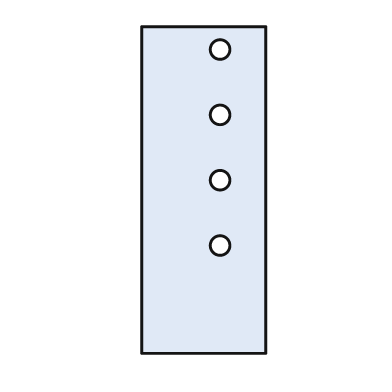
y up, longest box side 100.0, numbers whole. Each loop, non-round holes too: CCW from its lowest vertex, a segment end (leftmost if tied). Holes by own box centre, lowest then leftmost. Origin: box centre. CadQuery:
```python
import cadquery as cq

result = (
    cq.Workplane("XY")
    .moveTo(-19.0, -50.0)
    .lineTo(19.0, -50.0)
    .lineTo(19.0, 50.0)
    .lineTo(-19.0, 50.0)
    .close()
    .moveTo(5.0, -17.0)
    .circle(3.0)
    .moveTo(5.0, 3.0)
    .circle(3.0)
    .moveTo(5.0, 23.0)
    .circle(3.0)
    .moveTo(5.0, 43.0)
    .circle(3.0)
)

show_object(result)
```